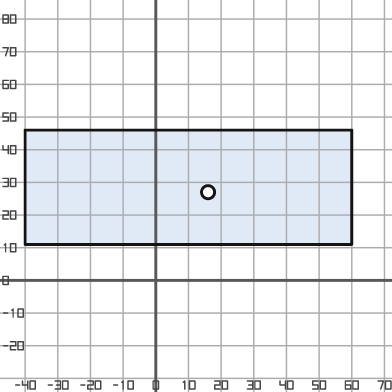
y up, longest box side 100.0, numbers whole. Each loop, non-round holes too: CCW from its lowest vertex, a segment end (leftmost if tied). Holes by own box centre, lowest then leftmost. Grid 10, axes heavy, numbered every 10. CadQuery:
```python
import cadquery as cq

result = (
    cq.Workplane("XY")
    .moveTo(-40.0, 11.0)
    .lineTo(60.0, 11.0)
    .lineTo(60.0, 46.0)
    .lineTo(-40.0, 46.0)
    .close()
    .moveTo(16.0, 27.0)
    .circle(2.0)
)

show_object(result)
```